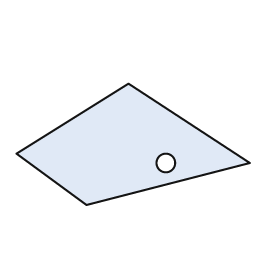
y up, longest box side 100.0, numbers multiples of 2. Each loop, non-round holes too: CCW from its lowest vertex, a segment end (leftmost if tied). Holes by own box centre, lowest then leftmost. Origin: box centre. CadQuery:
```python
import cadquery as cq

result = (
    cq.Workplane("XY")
    .moveTo(-20.0, -26.0)
    .lineTo(50.0, -8.0)
    .lineTo(-2.0, 26.0)
    .lineTo(-50.0, -4.0)
    .close()
    .moveTo(14.0, -8.0)
    .circle(4.0)
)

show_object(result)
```